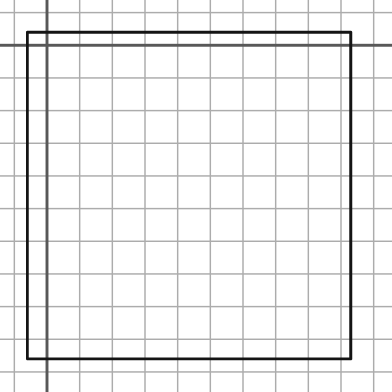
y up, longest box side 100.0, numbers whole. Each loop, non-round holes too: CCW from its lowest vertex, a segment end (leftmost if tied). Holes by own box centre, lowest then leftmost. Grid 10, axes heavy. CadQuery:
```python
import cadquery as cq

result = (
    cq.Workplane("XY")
    .moveTo(-6.0, -96.0)
    .lineTo(93.0, -96.0)
    .lineTo(93.0, 4.0)
    .lineTo(-6.0, 4.0)
    .close()
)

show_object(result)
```